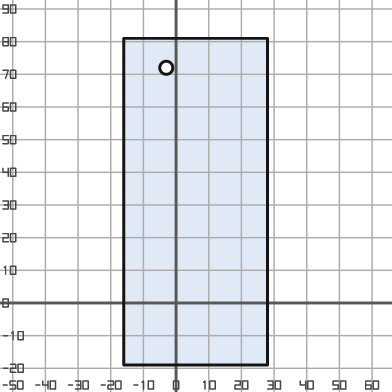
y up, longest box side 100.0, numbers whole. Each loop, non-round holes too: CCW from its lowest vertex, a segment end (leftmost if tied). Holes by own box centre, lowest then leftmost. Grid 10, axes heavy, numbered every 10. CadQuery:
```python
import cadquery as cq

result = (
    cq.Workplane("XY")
    .moveTo(-16.0, -19.0)
    .lineTo(28.0, -19.0)
    .lineTo(28.0, 81.0)
    .lineTo(-16.0, 81.0)
    .close()
    .moveTo(-3.0, 72.0)
    .circle(2.0)
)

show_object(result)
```